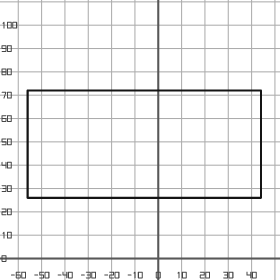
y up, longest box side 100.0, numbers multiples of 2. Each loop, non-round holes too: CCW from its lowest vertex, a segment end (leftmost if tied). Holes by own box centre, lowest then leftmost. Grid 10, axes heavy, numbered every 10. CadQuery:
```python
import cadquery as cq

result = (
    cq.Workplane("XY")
    .moveTo(-56.0, 26.0)
    .lineTo(44.0, 26.0)
    .lineTo(44.0, 72.0)
    .lineTo(-56.0, 72.0)
    .close()
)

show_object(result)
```